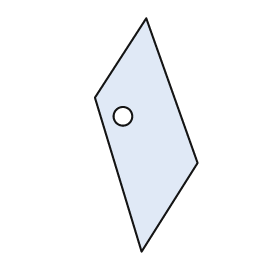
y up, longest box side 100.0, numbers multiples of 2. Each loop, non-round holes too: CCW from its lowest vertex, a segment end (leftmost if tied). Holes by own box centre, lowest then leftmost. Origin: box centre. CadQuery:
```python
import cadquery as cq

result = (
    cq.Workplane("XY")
    .moveTo(-2.0, -50.0)
    .lineTo(22.0, -12.0)
    .lineTo(0.0, 50.0)
    .lineTo(-22.0, 16.0)
    .close()
    .moveTo(-10.0, 8.0)
    .circle(4.0)
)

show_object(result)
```